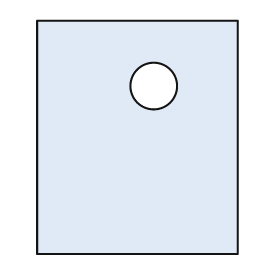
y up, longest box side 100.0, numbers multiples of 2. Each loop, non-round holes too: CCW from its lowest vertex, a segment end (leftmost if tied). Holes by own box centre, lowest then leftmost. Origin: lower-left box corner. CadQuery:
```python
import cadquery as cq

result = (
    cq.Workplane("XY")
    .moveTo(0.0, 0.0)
    .lineTo(86.0, 0.0)
    .lineTo(86.0, 100.0)
    .lineTo(0.0, 100.0)
    .close()
    .moveTo(50.0, 72.0)
    .circle(10.0)
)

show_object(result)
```